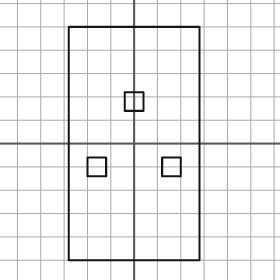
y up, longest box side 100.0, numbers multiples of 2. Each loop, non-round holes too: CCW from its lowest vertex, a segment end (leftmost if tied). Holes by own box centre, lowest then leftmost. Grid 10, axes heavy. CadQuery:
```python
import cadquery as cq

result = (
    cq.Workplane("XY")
    .moveTo(-28.0, -50.0)
    .lineTo(28.0, -50.0)
    .lineTo(28.0, 50.0)
    .lineTo(-28.0, 50.0)
    .close()
    .moveTo(-20.0, -14.0)
    .lineTo(-12.0, -14.0)
    .lineTo(-12.0, -6.0)
    .lineTo(-20.0, -6.0)
    .close()
    .moveTo(12.0, -14.0)
    .lineTo(20.0, -14.0)
    .lineTo(20.0, -6.0)
    .lineTo(12.0, -6.0)
    .close()
    .moveTo(-4.0, 14.0)
    .lineTo(4.0, 14.0)
    .lineTo(4.0, 22.0)
    .lineTo(-4.0, 22.0)
    .close()
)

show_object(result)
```